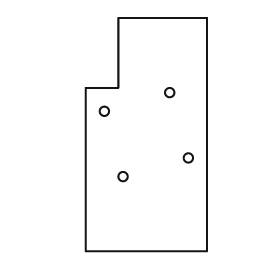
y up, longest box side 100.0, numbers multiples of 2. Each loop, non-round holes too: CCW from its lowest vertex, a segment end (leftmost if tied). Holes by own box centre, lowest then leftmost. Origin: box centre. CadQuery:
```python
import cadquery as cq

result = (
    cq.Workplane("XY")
    .moveTo(-26.0, -50.0)
    .lineTo(26.0, -50.0)
    .lineTo(26.0, 50.0)
    .lineTo(-12.0, 50.0)
    .lineTo(-12.0, 20.0)
    .lineTo(-26.0, 20.0)
    .close()
    .moveTo(-10.0, -18.0)
    .circle(2.0)
    .moveTo(18.0, -10.0)
    .circle(2.0)
    .moveTo(-18.0, 10.0)
    .circle(2.0)
    .moveTo(10.0, 18.0)
    .circle(2.0)
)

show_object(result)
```